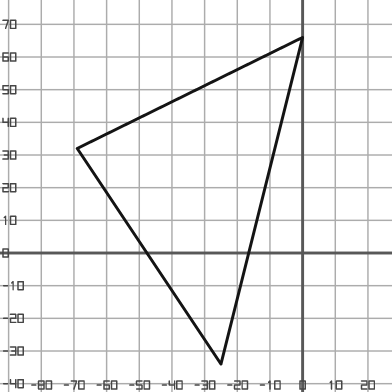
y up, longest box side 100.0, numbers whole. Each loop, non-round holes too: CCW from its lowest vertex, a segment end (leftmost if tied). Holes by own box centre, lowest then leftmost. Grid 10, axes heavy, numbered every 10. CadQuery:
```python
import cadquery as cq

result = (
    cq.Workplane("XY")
    .moveTo(-25.0, -34.0)
    .lineTo(0.0, 66.0)
    .lineTo(-69.0, 32.0)
    .close()
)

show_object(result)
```